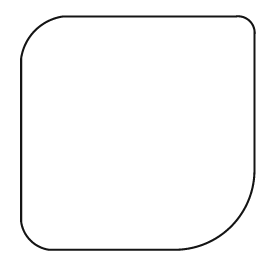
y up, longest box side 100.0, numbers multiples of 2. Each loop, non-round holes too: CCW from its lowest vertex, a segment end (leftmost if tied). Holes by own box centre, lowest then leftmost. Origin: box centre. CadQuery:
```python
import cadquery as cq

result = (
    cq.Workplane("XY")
    .moveTo(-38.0, -50.0)
    .lineTo(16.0, -50.0)
    .threePointArc((40.0, -40.0), (50.0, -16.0))
    .lineTo(50.0, 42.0)
    .threePointArc((48.0, 48.0), (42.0, 50.0))
    .lineTo(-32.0, 50.0)
    .threePointArc((-44.0, 44.0), (-50.0, 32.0))
    .lineTo(-50.0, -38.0)
    .threePointArc((-46.0, -46.0), (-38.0, -50.0))
    .close()
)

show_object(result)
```